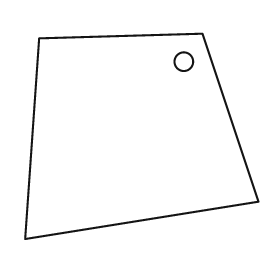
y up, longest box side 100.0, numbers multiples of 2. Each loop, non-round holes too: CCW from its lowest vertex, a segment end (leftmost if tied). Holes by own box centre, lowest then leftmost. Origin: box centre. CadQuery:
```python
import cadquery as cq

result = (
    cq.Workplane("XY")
    .moveTo(-50.0, -44.0)
    .lineTo(50.0, -28.0)
    .lineTo(26.0, 44.0)
    .lineTo(-44.0, 42.0)
    .close()
    .moveTo(18.0, 32.0)
    .circle(4.0)
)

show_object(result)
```